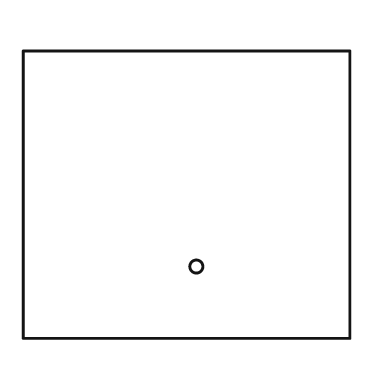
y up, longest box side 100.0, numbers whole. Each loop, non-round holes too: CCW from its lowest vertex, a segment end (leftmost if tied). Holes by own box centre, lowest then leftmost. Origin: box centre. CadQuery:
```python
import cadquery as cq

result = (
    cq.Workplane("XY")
    .moveTo(-50.0, -44.0)
    .lineTo(50.0, -44.0)
    .lineTo(50.0, 44.0)
    .lineTo(-50.0, 44.0)
    .close()
    .moveTo(3.0, -22.0)
    .circle(2.0)
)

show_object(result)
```